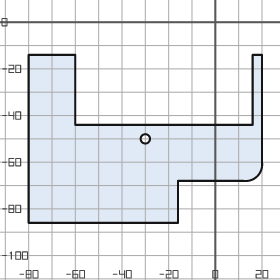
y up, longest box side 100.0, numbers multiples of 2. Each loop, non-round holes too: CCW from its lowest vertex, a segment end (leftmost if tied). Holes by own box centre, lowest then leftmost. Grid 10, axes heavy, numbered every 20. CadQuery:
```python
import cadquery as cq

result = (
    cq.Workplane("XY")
    .moveTo(-80.0, -86.0)
    .lineTo(-16.0, -86.0)
    .lineTo(-16.0, -68.0)
    .lineTo(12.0, -68.0)
    .threePointArc((18.0, -66.0), (20.0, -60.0))
    .lineTo(20.0, -14.0)
    .lineTo(16.0, -14.0)
    .lineTo(16.0, -44.0)
    .lineTo(-60.0, -44.0)
    .lineTo(-60.0, -14.0)
    .lineTo(-80.0, -14.0)
    .close()
    .moveTo(-30.0, -50.0)
    .circle(2.0)
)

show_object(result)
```